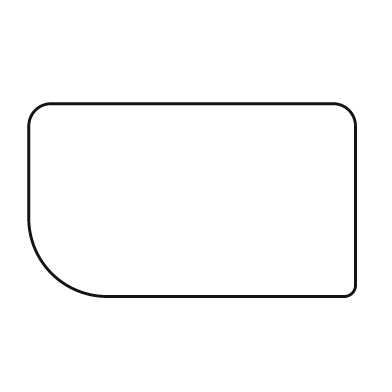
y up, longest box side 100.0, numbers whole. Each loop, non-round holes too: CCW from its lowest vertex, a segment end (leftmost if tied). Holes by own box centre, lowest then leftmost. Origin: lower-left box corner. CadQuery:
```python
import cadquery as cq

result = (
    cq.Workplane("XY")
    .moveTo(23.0, 0.0)
    .lineTo(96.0, 0.0)
    .threePointArc((99.0, 1.0), (100.0, 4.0))
    .lineTo(100.0, 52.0)
    .threePointArc((98.0, 57.0), (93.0, 59.0))
    .lineTo(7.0, 59.0)
    .threePointArc((2.0, 57.0), (0.0, 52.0))
    .lineTo(0.0, 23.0)
    .threePointArc((7.0, 7.0), (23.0, 0.0))
    .close()
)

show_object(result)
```